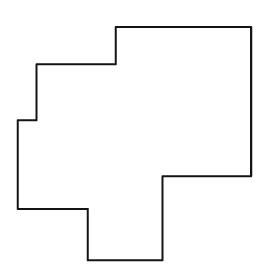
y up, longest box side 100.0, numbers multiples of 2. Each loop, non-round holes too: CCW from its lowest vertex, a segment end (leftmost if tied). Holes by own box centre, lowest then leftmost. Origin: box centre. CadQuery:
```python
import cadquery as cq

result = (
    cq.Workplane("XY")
    .moveTo(-20.0, -50.0)
    .lineTo(12.0, -50.0)
    .lineTo(12.0, -14.0)
    .lineTo(50.0, -14.0)
    .lineTo(50.0, 50.0)
    .lineTo(-8.0, 50.0)
    .lineTo(-8.0, 34.0)
    .lineTo(-42.0, 34.0)
    .lineTo(-42.0, 10.0)
    .lineTo(-50.0, 10.0)
    .lineTo(-50.0, -28.0)
    .lineTo(-20.0, -28.0)
    .close()
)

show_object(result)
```